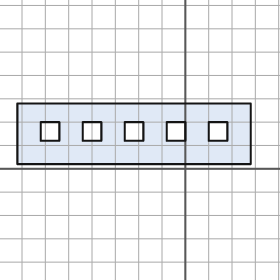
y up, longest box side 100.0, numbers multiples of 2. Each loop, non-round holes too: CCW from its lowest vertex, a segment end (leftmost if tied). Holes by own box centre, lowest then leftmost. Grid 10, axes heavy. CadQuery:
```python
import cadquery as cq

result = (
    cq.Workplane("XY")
    .moveTo(-72.0, 2.0)
    .lineTo(28.0, 2.0)
    .lineTo(28.0, 28.0)
    .lineTo(-72.0, 28.0)
    .close()
    .moveTo(-62.0, 12.0)
    .lineTo(-54.0, 12.0)
    .lineTo(-54.0, 20.0)
    .lineTo(-62.0, 20.0)
    .close()
    .moveTo(-44.0, 12.0)
    .lineTo(-36.0, 12.0)
    .lineTo(-36.0, 20.0)
    .lineTo(-44.0, 20.0)
    .close()
    .moveTo(-26.0, 12.0)
    .lineTo(-18.0, 12.0)
    .lineTo(-18.0, 20.0)
    .lineTo(-26.0, 20.0)
    .close()
    .moveTo(-8.0, 12.0)
    .lineTo(0.0, 12.0)
    .lineTo(0.0, 20.0)
    .lineTo(-8.0, 20.0)
    .close()
    .moveTo(10.0, 12.0)
    .lineTo(18.0, 12.0)
    .lineTo(18.0, 20.0)
    .lineTo(10.0, 20.0)
    .close()
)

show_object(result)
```